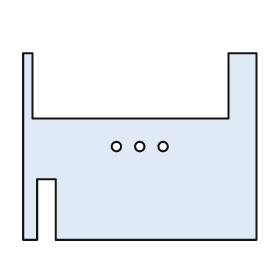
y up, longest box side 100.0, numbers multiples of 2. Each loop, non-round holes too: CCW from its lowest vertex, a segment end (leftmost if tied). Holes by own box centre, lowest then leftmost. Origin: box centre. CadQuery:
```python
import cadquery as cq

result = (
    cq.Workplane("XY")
    .moveTo(-50.0, -40.0)
    .lineTo(-44.0, -40.0)
    .lineTo(-44.0, -14.0)
    .lineTo(-36.0, -14.0)
    .lineTo(-36.0, -40.0)
    .lineTo(50.0, -40.0)
    .lineTo(50.0, 40.0)
    .lineTo(38.0, 40.0)
    .lineTo(38.0, 12.0)
    .lineTo(-46.0, 12.0)
    .lineTo(-46.0, 40.0)
    .lineTo(-50.0, 40.0)
    .close()
    .moveTo(-10.0, 0.0)
    .circle(2.0)
    .moveTo(0.0, 0.0)
    .circle(2.0)
    .moveTo(10.0, 0.0)
    .circle(2.0)
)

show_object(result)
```